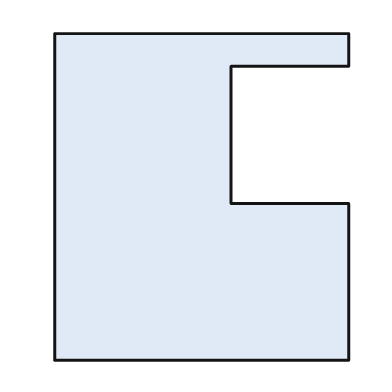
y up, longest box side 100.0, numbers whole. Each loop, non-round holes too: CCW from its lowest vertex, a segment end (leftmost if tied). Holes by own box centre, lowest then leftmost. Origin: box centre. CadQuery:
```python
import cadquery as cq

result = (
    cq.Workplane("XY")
    .moveTo(-45.0, -50.0)
    .lineTo(45.0, -50.0)
    .lineTo(45.0, -2.0)
    .lineTo(9.0, -2.0)
    .lineTo(9.0, 40.0)
    .lineTo(45.0, 40.0)
    .lineTo(45.0, 50.0)
    .lineTo(-45.0, 50.0)
    .close()
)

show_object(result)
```